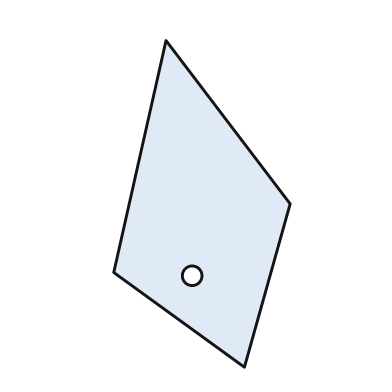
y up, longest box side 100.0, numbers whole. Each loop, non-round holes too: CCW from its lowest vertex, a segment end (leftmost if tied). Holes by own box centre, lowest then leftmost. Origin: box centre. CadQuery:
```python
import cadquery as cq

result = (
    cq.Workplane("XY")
    .moveTo(13.0, -50.0)
    .lineTo(27.0, 0.0)
    .lineTo(-11.0, 50.0)
    .lineTo(-27.0, -21.0)
    .close()
    .moveTo(-3.0, -22.0)
    .circle(3.0)
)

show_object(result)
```